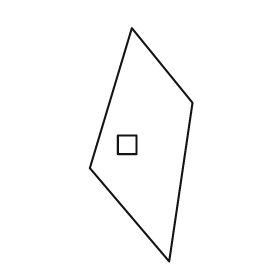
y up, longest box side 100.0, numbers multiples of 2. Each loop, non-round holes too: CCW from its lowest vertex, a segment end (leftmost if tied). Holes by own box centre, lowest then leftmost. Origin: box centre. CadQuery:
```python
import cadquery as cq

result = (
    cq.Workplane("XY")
    .moveTo(12.0, -50.0)
    .lineTo(22.0, 18.0)
    .lineTo(-4.0, 50.0)
    .lineTo(-22.0, -10.0)
    .close()
    .moveTo(-10.0, -4.0)
    .lineTo(-2.0, -4.0)
    .lineTo(-2.0, 4.0)
    .lineTo(-10.0, 4.0)
    .close()
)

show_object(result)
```